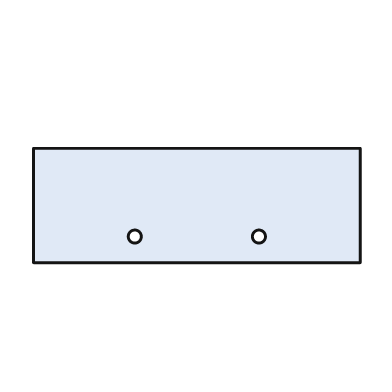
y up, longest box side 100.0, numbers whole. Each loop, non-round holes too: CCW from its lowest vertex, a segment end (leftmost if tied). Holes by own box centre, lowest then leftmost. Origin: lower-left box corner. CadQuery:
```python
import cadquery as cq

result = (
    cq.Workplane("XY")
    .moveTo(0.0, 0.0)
    .lineTo(100.0, 0.0)
    .lineTo(100.0, 35.0)
    .lineTo(0.0, 35.0)
    .close()
    .moveTo(31.0, 8.0)
    .circle(2.0)
    .moveTo(69.0, 8.0)
    .circle(2.0)
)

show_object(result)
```